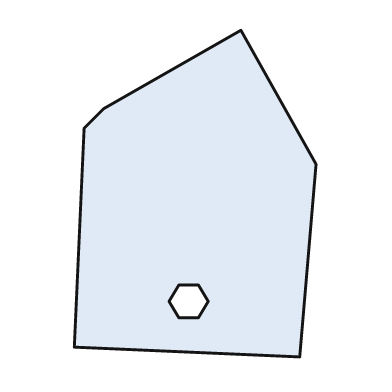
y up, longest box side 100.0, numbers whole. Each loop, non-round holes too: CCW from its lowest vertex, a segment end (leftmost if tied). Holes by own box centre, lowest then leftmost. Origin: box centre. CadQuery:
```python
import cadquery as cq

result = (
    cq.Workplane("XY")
    .moveTo(32.0, -50.0)
    .lineTo(37.0, 9.0)
    .lineTo(14.0, 50.0)
    .lineTo(-28.0, 26.0)
    .lineTo(-34.0, 20.0)
    .lineTo(-37.0, -47.0)
    .close()
    .moveTo(-5.0, -38.0)
    .lineTo(1.0, -38.0)
    .lineTo(4.0, -33.0)
    .lineTo(1.0, -28.0)
    .lineTo(-5.0, -28.0)
    .lineTo(-8.0, -33.0)
    .close()
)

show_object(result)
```